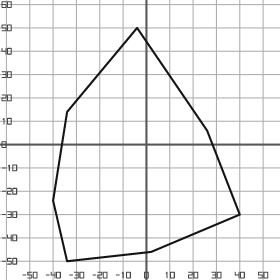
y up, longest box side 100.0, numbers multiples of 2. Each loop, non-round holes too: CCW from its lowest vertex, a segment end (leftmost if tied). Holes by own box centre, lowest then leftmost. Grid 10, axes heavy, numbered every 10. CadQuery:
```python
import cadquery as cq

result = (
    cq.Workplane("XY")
    .moveTo(-34.0, -50.0)
    .lineTo(2.0, -46.0)
    .lineTo(40.0, -30.0)
    .lineTo(26.0, 6.0)
    .lineTo(-4.0, 50.0)
    .lineTo(-34.0, 14.0)
    .lineTo(-40.0, -24.0)
    .close()
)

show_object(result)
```